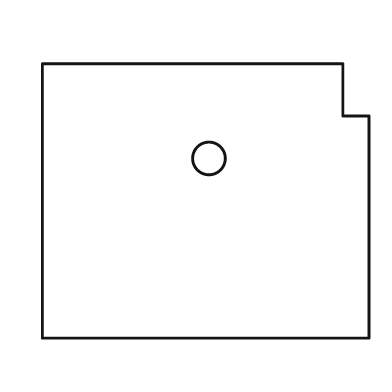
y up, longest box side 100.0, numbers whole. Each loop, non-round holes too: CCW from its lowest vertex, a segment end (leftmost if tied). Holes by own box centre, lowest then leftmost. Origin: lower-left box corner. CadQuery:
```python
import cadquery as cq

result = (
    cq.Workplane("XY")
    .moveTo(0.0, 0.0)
    .lineTo(100.0, 0.0)
    .lineTo(100.0, 68.0)
    .lineTo(92.0, 68.0)
    .lineTo(92.0, 84.0)
    .lineTo(0.0, 84.0)
    .close()
    .moveTo(51.0, 55.0)
    .circle(5.0)
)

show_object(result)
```